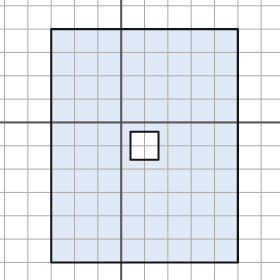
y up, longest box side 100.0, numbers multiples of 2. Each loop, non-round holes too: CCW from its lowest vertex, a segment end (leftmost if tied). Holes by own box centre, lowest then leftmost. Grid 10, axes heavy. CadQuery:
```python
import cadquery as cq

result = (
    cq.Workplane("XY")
    .moveTo(-30.0, -60.0)
    .lineTo(50.0, -60.0)
    .lineTo(50.0, 40.0)
    .lineTo(-30.0, 40.0)
    .close()
    .moveTo(4.0, -16.0)
    .lineTo(16.0, -16.0)
    .lineTo(16.0, -4.0)
    .lineTo(4.0, -4.0)
    .close()
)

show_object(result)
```